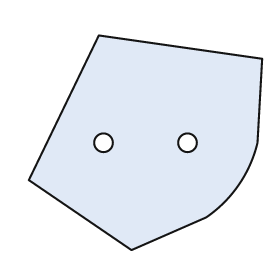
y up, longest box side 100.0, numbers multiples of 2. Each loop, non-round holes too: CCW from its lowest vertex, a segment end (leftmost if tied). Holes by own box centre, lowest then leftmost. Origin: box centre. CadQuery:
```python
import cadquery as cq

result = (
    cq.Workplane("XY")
    .moveTo(-6.0, -46.0)
    .lineTo(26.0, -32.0)
    .threePointArc((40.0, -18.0), (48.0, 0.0))
    .lineTo(50.0, 36.0)
    .lineTo(-20.0, 46.0)
    .lineTo(-50.0, -16.0)
    .close()
    .moveTo(-18.0, 0.0)
    .circle(4.0)
    .moveTo(18.0, 0.0)
    .circle(4.0)
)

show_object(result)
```